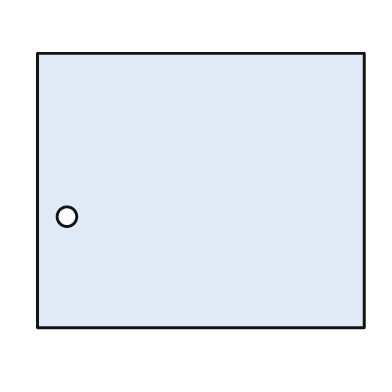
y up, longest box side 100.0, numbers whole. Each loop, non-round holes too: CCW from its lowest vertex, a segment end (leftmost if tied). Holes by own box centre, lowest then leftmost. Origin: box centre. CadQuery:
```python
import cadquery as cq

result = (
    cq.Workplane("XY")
    .moveTo(-50.0, -42.0)
    .lineTo(50.0, -42.0)
    .lineTo(50.0, 42.0)
    .lineTo(-50.0, 42.0)
    .close()
    .moveTo(-41.0, -8.0)
    .circle(3.0)
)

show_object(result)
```